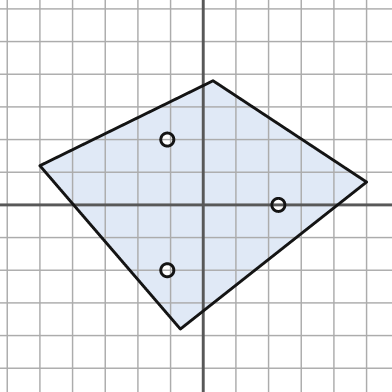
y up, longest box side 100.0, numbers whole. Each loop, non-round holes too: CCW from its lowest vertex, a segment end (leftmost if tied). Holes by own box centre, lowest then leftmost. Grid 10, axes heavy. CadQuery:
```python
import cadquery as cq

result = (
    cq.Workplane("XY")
    .moveTo(-7.0, -38.0)
    .lineTo(50.0, 7.0)
    .lineTo(3.0, 38.0)
    .lineTo(-50.0, 12.0)
    .close()
    .moveTo(-11.0, -20.0)
    .circle(2.0)
    .moveTo(23.0, 0.0)
    .circle(2.0)
    .moveTo(-11.0, 20.0)
    .circle(2.0)
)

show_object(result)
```